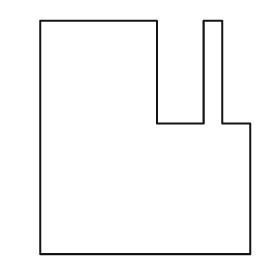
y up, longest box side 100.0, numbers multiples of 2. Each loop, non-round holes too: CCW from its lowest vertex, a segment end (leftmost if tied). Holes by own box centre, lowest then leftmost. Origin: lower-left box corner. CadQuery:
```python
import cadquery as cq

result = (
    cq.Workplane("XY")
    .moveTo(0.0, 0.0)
    .lineTo(90.0, 0.0)
    .lineTo(90.0, 56.0)
    .lineTo(78.0, 56.0)
    .lineTo(78.0, 100.0)
    .lineTo(70.0, 100.0)
    .lineTo(70.0, 56.0)
    .lineTo(50.0, 56.0)
    .lineTo(50.0, 100.0)
    .lineTo(0.0, 100.0)
    .close()
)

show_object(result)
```